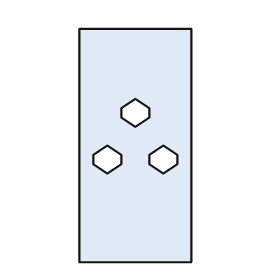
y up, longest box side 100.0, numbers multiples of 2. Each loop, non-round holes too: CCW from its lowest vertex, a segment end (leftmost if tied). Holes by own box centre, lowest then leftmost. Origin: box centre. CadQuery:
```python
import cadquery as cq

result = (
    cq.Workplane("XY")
    .moveTo(-24.0, -50.0)
    .lineTo(24.0, -50.0)
    .lineTo(24.0, 50.0)
    .lineTo(-24.0, 50.0)
    .close()
    .moveTo(-12.0, -12.0)
    .lineTo(-6.0, -8.0)
    .lineTo(-6.0, -4.0)
    .lineTo(-12.0, 0.0)
    .lineTo(-18.0, -4.0)
    .lineTo(-18.0, -8.0)
    .close()
    .moveTo(12.0, -12.0)
    .lineTo(18.0, -8.0)
    .lineTo(18.0, -4.0)
    .lineTo(12.0, 0.0)
    .lineTo(6.0, -4.0)
    .lineTo(6.0, -8.0)
    .close()
    .moveTo(0.0, 8.0)
    .lineTo(6.0, 12.0)
    .lineTo(6.0, 16.0)
    .lineTo(0.0, 20.0)
    .lineTo(-6.0, 16.0)
    .lineTo(-6.0, 12.0)
    .close()
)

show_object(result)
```